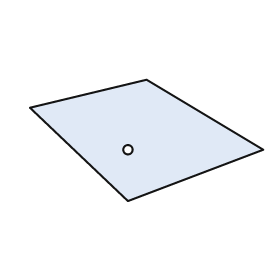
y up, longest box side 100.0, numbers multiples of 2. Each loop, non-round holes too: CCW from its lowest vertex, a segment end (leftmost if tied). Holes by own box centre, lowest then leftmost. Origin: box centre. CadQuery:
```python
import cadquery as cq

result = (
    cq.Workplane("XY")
    .moveTo(-8.0, -26.0)
    .lineTo(50.0, -4.0)
    .lineTo(0.0, 26.0)
    .lineTo(-50.0, 14.0)
    .close()
    .moveTo(-8.0, -4.0)
    .circle(2.0)
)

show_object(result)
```